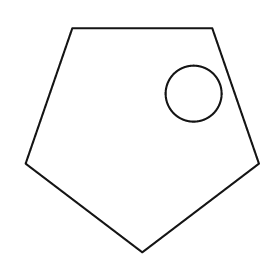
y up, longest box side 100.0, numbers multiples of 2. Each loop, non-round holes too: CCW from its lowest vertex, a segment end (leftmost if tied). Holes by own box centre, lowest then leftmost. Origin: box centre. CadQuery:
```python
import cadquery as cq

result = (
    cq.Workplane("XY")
    .moveTo(0.0, -48.0)
    .lineTo(50.0, -10.0)
    .lineTo(30.0, 48.0)
    .lineTo(-30.0, 48.0)
    .lineTo(-50.0, -10.0)
    .close()
    .moveTo(22.0, 20.0)
    .circle(12.0)
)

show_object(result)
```